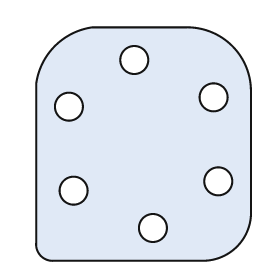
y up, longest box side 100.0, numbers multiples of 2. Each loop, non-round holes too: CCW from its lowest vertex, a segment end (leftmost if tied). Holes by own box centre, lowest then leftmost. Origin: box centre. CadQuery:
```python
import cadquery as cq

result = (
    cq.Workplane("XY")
    .moveTo(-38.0, -50.0)
    .lineTo(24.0, -50.0)
    .threePointArc((40.0, -44.0), (46.0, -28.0))
    .lineTo(46.0, 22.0)
    .threePointArc((38.0, 42.0), (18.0, 50.0))
    .lineTo(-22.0, 50.0)
    .threePointArc((-38.0, 42.0), (-46.0, 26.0))
    .lineTo(-46.0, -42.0)
    .threePointArc((-44.0, -48.0), (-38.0, -50.0))
    .close()
    .moveTo(4.0, -36.0)
    .circle(6.0)
    .moveTo(-30.0, -20.0)
    .circle(6.0)
    .moveTo(32.0, -16.0)
    .circle(6.0)
    .moveTo(-32.0, 16.0)
    .circle(6.0)
    .moveTo(30.0, 20.0)
    .circle(6.0)
    .moveTo(-4.0, 36.0)
    .circle(6.0)
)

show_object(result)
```